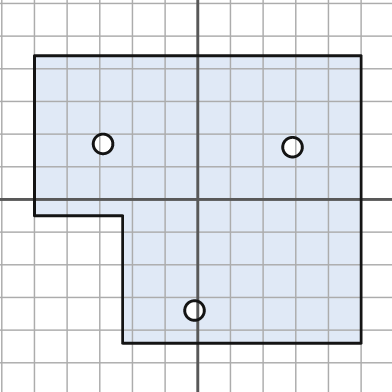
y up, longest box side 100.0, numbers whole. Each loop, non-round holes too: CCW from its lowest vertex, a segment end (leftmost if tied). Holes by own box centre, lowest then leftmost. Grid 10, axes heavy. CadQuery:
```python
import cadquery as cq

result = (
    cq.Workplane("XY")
    .moveTo(-23.0, -44.0)
    .lineTo(50.0, -44.0)
    .lineTo(50.0, 44.0)
    .lineTo(-50.0, 44.0)
    .lineTo(-50.0, -5.0)
    .lineTo(-23.0, -5.0)
    .close()
    .moveTo(-1.0, -34.0)
    .circle(3.0)
    .moveTo(29.0, 16.0)
    .circle(3.0)
    .moveTo(-29.0, 17.0)
    .circle(3.0)
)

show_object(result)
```